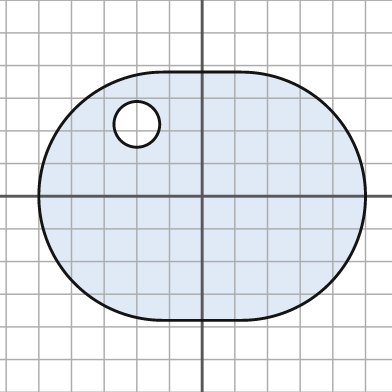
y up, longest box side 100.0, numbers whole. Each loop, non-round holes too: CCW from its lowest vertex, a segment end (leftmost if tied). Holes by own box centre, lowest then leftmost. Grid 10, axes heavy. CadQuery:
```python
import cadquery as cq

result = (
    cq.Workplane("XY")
    .moveTo(-12.0, -38.0)
    .lineTo(12.0, -38.0)
    .threePointArc((50.0, 0.0), (12.0, 38.0))
    .lineTo(-12.0, 38.0)
    .threePointArc((-50.0, 0.0), (-12.0, -38.0))
    .close()
    .moveTo(-20.0, 22.0)
    .circle(7.0)
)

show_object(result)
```